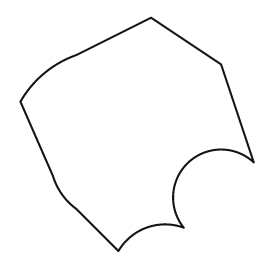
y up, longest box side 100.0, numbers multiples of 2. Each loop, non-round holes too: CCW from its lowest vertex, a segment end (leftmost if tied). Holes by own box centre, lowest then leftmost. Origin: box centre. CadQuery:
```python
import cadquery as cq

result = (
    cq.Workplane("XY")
    .moveTo(-8.0, -50.0)
    .threePointArc((4.0, -40.0), (20.0, -40.0))
    .threePointArc((22.0, -12.0), (50.0, -12.0))
    .lineTo(36.0, 30.0)
    .lineTo(6.0, 50.0)
    .lineTo(-26.0, 34.0)
    .threePointArc((-40.0, 26.0), (-50.0, 14.0))
    .lineTo(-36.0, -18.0)
    .threePointArc((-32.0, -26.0), (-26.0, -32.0))
    .close()
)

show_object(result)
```